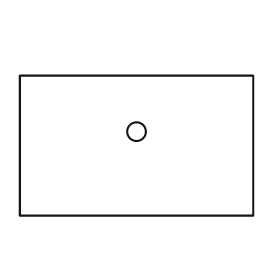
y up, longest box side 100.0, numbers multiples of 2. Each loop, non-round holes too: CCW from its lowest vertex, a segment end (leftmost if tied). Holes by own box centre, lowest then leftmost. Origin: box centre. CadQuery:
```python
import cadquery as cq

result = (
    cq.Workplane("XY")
    .moveTo(-50.0, -30.0)
    .lineTo(50.0, -30.0)
    .lineTo(50.0, 30.0)
    .lineTo(-50.0, 30.0)
    .close()
    .moveTo(0.0, 6.0)
    .circle(4.0)
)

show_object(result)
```